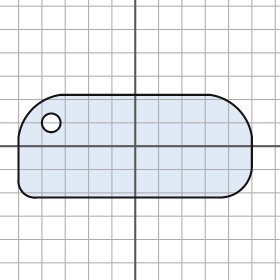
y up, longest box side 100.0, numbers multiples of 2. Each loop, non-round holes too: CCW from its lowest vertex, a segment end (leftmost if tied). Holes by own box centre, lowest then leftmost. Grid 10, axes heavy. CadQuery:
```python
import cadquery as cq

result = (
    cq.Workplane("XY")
    .moveTo(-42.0, -22.0)
    .lineTo(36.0, -22.0)
    .threePointArc((46.0, -18.0), (50.0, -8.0))
    .lineTo(50.0, 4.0)
    .threePointArc((44.0, 16.0), (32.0, 22.0))
    .lineTo(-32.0, 22.0)
    .threePointArc((-44.0, 16.0), (-50.0, 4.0))
    .lineTo(-50.0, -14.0)
    .threePointArc((-48.0, -20.0), (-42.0, -22.0))
    .close()
    .moveTo(-36.0, 10.0)
    .circle(4.0)
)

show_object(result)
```